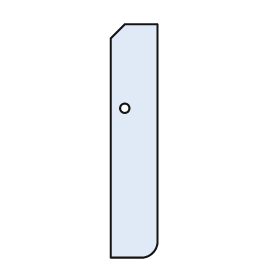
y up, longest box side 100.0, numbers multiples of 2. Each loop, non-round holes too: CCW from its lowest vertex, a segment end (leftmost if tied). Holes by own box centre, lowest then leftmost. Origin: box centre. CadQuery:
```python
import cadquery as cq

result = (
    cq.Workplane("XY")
    .moveTo(-10.0, -50.0)
    .lineTo(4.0, -50.0)
    .threePointArc((8.0, -48.0), (10.0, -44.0))
    .lineTo(10.0, 50.0)
    .lineTo(-4.0, 50.0)
    .lineTo(-10.0, 44.0)
    .close()
    .moveTo(-4.0, 14.0)
    .circle(2.0)
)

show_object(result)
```